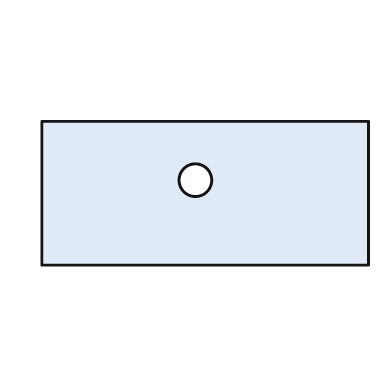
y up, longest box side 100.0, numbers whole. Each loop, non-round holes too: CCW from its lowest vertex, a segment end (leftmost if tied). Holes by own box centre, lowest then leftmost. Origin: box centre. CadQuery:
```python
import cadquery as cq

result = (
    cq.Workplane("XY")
    .moveTo(-50.0, -22.0)
    .lineTo(50.0, -22.0)
    .lineTo(50.0, 22.0)
    .lineTo(-50.0, 22.0)
    .close()
    .moveTo(-3.0, 4.0)
    .circle(5.0)
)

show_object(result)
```